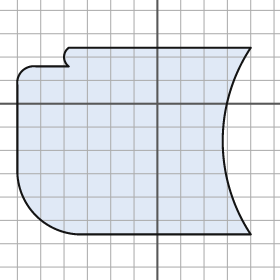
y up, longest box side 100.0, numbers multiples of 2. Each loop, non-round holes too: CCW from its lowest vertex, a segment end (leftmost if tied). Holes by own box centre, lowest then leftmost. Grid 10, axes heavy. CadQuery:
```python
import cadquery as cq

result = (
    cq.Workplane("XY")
    .moveTo(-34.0, -56.0)
    .lineTo(40.0, -56.0)
    .threePointArc((28.0, -16.0), (40.0, 24.0))
    .lineTo(-38.0, 24.0)
    .threePointArc((-40.0, 20.0), (-38.0, 16.0))
    .lineTo(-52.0, 16.0)
    .threePointArc((-58.0, 14.0), (-60.0, 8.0))
    .lineTo(-60.0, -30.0)
    .threePointArc((-52.0, -48.0), (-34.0, -56.0))
    .close()
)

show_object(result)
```